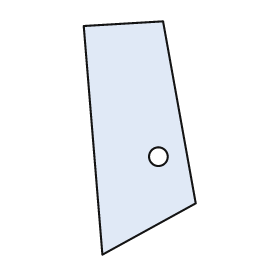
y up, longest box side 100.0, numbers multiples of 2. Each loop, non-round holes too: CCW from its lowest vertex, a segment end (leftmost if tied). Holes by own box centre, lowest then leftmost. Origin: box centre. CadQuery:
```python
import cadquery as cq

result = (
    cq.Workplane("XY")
    .moveTo(-16.0, -50.0)
    .lineTo(24.0, -28.0)
    .lineTo(10.0, 50.0)
    .lineTo(-24.0, 48.0)
    .close()
    .moveTo(8.0, -8.0)
    .circle(4.0)
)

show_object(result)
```